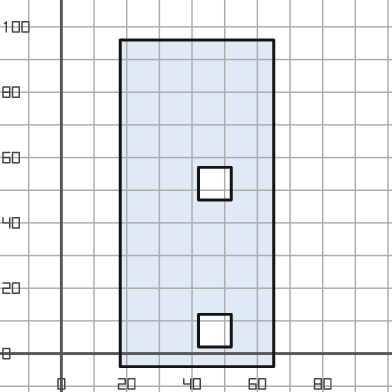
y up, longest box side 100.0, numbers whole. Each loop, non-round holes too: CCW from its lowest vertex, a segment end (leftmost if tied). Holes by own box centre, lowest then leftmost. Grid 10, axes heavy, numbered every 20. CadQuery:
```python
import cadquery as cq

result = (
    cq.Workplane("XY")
    .moveTo(18.0, -4.0)
    .lineTo(65.0, -4.0)
    .lineTo(65.0, 96.0)
    .lineTo(18.0, 96.0)
    .close()
    .moveTo(42.0, 2.0)
    .lineTo(52.0, 2.0)
    .lineTo(52.0, 12.0)
    .lineTo(42.0, 12.0)
    .close()
    .moveTo(42.0, 47.0)
    .lineTo(52.0, 47.0)
    .lineTo(52.0, 57.0)
    .lineTo(42.0, 57.0)
    .close()
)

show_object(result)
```